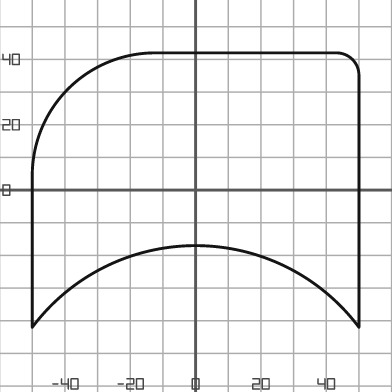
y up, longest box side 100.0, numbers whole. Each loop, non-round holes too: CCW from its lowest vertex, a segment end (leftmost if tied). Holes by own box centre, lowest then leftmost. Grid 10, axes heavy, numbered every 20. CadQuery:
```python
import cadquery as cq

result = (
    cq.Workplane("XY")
    .moveTo(-50.0, -42.0)
    .threePointArc((0.0, -17.0), (50.0, -42.0))
    .lineTo(50.0, 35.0)
    .threePointArc((48.0, 40.0), (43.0, 42.0))
    .lineTo(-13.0, 42.0)
    .threePointArc((-39.0, 31.0), (-50.0, 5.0))
    .close()
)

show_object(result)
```